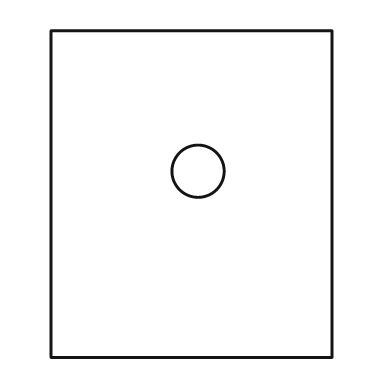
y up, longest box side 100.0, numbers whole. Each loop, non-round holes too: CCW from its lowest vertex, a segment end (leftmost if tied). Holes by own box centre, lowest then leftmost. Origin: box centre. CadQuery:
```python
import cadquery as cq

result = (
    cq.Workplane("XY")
    .moveTo(-43.0, -50.0)
    .lineTo(43.0, -50.0)
    .lineTo(43.0, 50.0)
    .lineTo(-43.0, 50.0)
    .close()
    .moveTo(2.0, 7.0)
    .circle(8.0)
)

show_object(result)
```